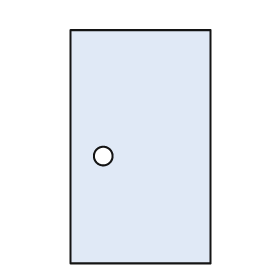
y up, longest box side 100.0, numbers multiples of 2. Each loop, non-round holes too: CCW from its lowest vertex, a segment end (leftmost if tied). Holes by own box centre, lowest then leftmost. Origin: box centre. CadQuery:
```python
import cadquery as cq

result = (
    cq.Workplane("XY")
    .moveTo(-30.0, -50.0)
    .lineTo(30.0, -50.0)
    .lineTo(30.0, 50.0)
    .lineTo(-30.0, 50.0)
    .close()
    .moveTo(-16.0, -4.0)
    .circle(4.0)
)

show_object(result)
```